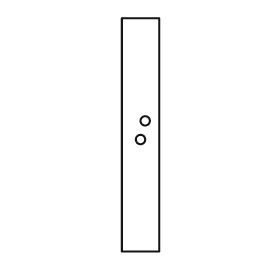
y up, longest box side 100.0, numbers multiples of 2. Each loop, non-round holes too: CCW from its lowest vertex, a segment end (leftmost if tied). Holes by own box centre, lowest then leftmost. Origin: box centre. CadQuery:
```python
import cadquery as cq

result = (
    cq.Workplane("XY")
    .moveTo(-8.0, -50.0)
    .lineTo(8.0, -50.0)
    .lineTo(8.0, 50.0)
    .lineTo(-8.0, 50.0)
    .close()
    .moveTo(0.0, -2.0)
    .circle(2.0)
    .moveTo(2.0, 6.0)
    .circle(2.0)
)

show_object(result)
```